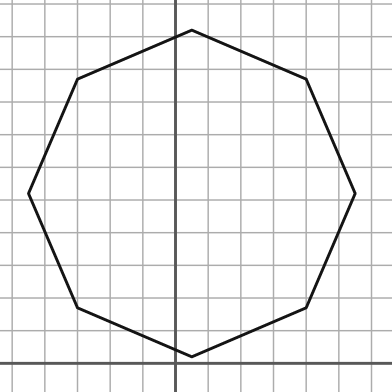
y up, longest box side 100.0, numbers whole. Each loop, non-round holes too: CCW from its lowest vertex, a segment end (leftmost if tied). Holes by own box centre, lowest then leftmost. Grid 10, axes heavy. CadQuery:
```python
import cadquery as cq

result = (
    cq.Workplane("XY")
    .moveTo(5.0, 2.0)
    .lineTo(40.0, 17.0)
    .lineTo(55.0, 52.0)
    .lineTo(40.0, 87.0)
    .lineTo(5.0, 102.0)
    .lineTo(-30.0, 87.0)
    .lineTo(-45.0, 52.0)
    .lineTo(-30.0, 17.0)
    .close()
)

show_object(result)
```